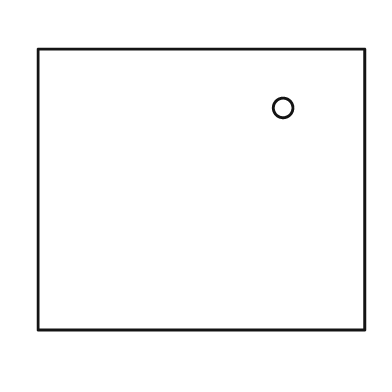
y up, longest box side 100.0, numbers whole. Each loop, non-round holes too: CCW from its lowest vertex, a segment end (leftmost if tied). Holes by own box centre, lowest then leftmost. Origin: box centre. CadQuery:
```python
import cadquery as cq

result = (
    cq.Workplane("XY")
    .moveTo(-50.0, -43.0)
    .lineTo(50.0, -43.0)
    .lineTo(50.0, 43.0)
    .lineTo(-50.0, 43.0)
    .close()
    .moveTo(25.0, 25.0)
    .circle(3.0)
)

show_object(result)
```